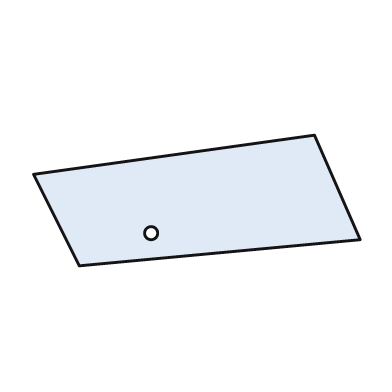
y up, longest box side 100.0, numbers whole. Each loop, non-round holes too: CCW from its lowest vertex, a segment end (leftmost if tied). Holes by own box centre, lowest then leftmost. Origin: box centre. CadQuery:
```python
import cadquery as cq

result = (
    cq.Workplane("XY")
    .moveTo(-36.0, -20.0)
    .lineTo(50.0, -12.0)
    .lineTo(36.0, 20.0)
    .lineTo(-50.0, 8.0)
    .close()
    .moveTo(-14.0, -10.0)
    .circle(2.0)
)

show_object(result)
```